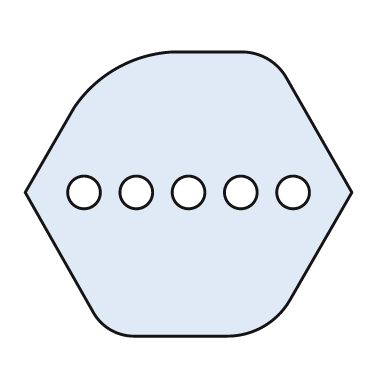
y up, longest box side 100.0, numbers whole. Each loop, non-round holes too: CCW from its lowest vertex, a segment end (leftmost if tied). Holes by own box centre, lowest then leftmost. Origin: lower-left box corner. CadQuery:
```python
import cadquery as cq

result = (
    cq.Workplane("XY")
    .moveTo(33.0, 0.0)
    .lineTo(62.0, 0.0)
    .threePointArc((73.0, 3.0), (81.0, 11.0))
    .lineTo(100.0, 44.0)
    .lineTo(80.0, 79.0)
    .threePointArc((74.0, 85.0), (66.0, 87.0))
    .lineTo(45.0, 87.0)
    .threePointArc((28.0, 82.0), (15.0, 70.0))
    .lineTo(0.0, 44.0)
    .lineTo(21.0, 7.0)
    .threePointArc((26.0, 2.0), (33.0, 0.0))
    .close()
    .moveTo(18.0, 44.0)
    .circle(5.0)
    .moveTo(34.0, 44.0)
    .circle(5.0)
    .moveTo(50.0, 44.0)
    .circle(5.0)
    .moveTo(66.0, 44.0)
    .circle(5.0)
    .moveTo(82.0, 44.0)
    .circle(5.0)
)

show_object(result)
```